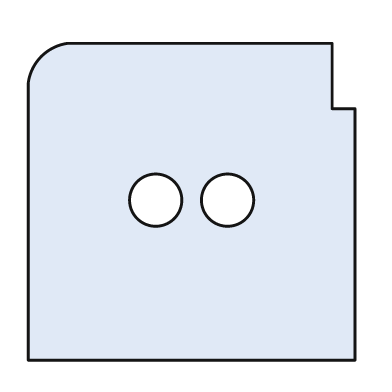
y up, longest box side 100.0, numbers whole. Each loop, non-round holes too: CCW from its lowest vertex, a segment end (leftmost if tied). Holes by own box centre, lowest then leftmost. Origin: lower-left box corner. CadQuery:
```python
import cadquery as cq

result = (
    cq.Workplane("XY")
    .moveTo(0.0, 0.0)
    .lineTo(100.0, 0.0)
    .lineTo(100.0, 77.0)
    .lineTo(93.0, 77.0)
    .lineTo(93.0, 97.0)
    .lineTo(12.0, 97.0)
    .threePointArc((4.0, 93.0), (0.0, 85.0))
    .close()
    .moveTo(39.0, 49.0)
    .circle(8.0)
    .moveTo(61.0, 49.0)
    .circle(8.0)
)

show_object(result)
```